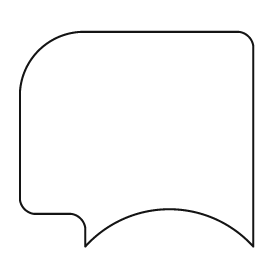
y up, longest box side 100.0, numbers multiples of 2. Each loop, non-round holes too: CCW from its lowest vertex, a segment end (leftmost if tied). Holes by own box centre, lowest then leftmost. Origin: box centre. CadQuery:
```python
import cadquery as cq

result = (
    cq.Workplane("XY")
    .moveTo(-22.0, -46.0)
    .threePointArc((14.0, -30.0), (50.0, -46.0))
    .lineTo(50.0, 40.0)
    .threePointArc((48.0, 44.0), (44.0, 46.0))
    .lineTo(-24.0, 46.0)
    .threePointArc((-42.0, 38.0), (-50.0, 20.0))
    .lineTo(-50.0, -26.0)
    .threePointArc((-48.0, -30.0), (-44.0, -32.0))
    .lineTo(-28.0, -32.0)
    .threePointArc((-24.0, -34.0), (-22.0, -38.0))
    .close()
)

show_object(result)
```